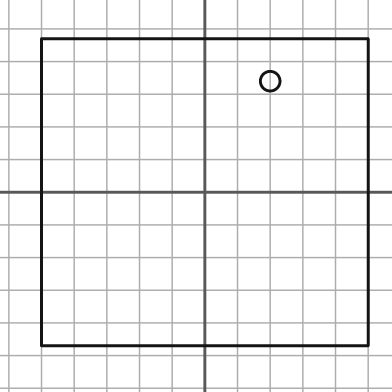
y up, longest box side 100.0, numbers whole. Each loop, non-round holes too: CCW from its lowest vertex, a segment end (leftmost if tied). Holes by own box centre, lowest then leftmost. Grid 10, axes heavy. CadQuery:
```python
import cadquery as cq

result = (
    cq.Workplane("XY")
    .moveTo(-50.0, -47.0)
    .lineTo(50.0, -47.0)
    .lineTo(50.0, 47.0)
    .lineTo(-50.0, 47.0)
    .close()
    .moveTo(20.0, 34.0)
    .circle(3.0)
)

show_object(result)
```